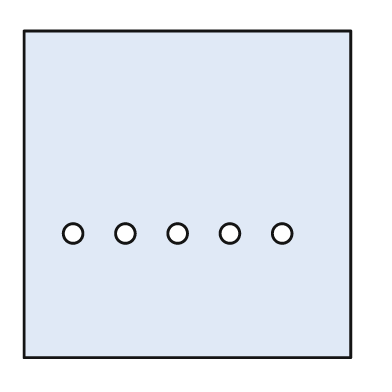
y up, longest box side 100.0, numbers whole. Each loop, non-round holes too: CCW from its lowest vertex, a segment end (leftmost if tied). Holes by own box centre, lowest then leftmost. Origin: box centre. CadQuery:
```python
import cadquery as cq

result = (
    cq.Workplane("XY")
    .moveTo(-50.0, -50.0)
    .lineTo(50.0, -50.0)
    .lineTo(50.0, 50.0)
    .lineTo(-50.0, 50.0)
    .close()
    .moveTo(-35.0, -12.0)
    .circle(3.0)
    .moveTo(-19.0, -12.0)
    .circle(3.0)
    .moveTo(-3.0, -12.0)
    .circle(3.0)
    .moveTo(13.0, -12.0)
    .circle(3.0)
    .moveTo(29.0, -12.0)
    .circle(3.0)
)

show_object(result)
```